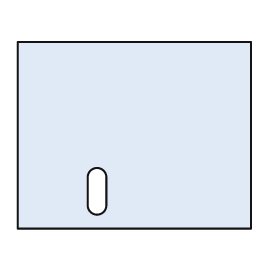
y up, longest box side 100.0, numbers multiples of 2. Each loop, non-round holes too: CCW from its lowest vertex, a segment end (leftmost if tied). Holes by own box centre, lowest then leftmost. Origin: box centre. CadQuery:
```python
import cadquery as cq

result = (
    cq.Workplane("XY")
    .moveTo(-50.0, -40.0)
    .lineTo(50.0, -40.0)
    .lineTo(50.0, 40.0)
    .lineTo(-50.0, 40.0)
    .close()
    .moveTo(-20.0, -30.0)
    .threePointArc((-16.0, -34.0), (-12.0, -30.0))
    .lineTo(-12.0, -18.0)
    .threePointArc((-16.0, -14.0), (-20.0, -18.0))
    .close()
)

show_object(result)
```